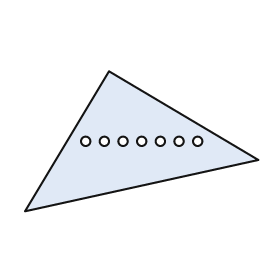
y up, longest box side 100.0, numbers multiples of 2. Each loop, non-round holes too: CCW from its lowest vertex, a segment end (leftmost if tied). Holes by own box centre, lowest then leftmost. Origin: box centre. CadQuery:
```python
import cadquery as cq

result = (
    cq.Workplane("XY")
    .moveTo(-50.0, -30.0)
    .lineTo(50.0, -8.0)
    .lineTo(-14.0, 30.0)
    .close()
    .moveTo(-24.0, 0.0)
    .circle(2.0)
    .moveTo(-16.0, 0.0)
    .circle(2.0)
    .moveTo(-8.0, 0.0)
    .circle(2.0)
    .moveTo(0.0, 0.0)
    .circle(2.0)
    .moveTo(8.0, 0.0)
    .circle(2.0)
    .moveTo(16.0, 0.0)
    .circle(2.0)
    .moveTo(24.0, 0.0)
    .circle(2.0)
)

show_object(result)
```